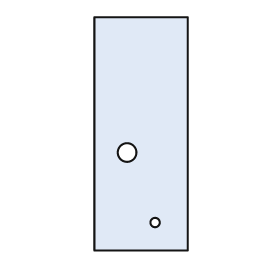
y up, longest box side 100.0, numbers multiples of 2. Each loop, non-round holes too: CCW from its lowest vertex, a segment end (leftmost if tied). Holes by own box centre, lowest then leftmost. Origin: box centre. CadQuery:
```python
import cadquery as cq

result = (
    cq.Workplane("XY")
    .moveTo(-20.0, -50.0)
    .lineTo(20.0, -50.0)
    .lineTo(20.0, 50.0)
    .lineTo(-20.0, 50.0)
    .close()
    .moveTo(6.0, -38.0)
    .circle(2.0)
    .moveTo(-6.0, -8.0)
    .circle(4.0)
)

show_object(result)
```